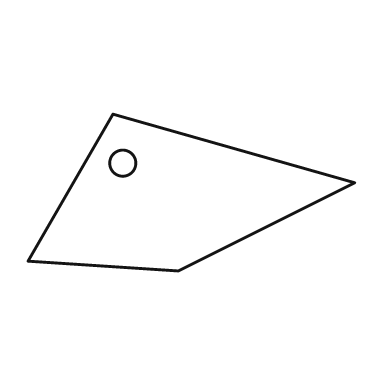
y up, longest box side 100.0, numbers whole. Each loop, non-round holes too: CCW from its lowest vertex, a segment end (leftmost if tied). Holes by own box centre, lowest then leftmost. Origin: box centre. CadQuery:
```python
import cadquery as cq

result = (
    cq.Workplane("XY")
    .moveTo(-4.0, -24.0)
    .lineTo(50.0, 3.0)
    .lineTo(-24.0, 24.0)
    .lineTo(-50.0, -21.0)
    .close()
    .moveTo(-21.0, 9.0)
    .circle(4.0)
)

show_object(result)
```